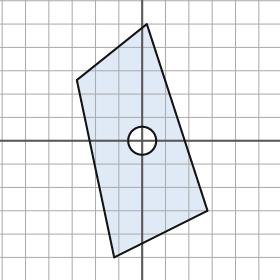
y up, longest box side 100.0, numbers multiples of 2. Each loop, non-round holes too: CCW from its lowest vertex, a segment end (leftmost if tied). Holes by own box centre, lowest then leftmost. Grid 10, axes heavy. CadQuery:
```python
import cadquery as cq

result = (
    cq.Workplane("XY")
    .moveTo(-12.0, -50.0)
    .lineTo(28.0, -30.0)
    .lineTo(2.0, 50.0)
    .lineTo(-28.0, 26.0)
    .close()
    .moveTo(0.0, 0.0)
    .circle(6.0)
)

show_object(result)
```